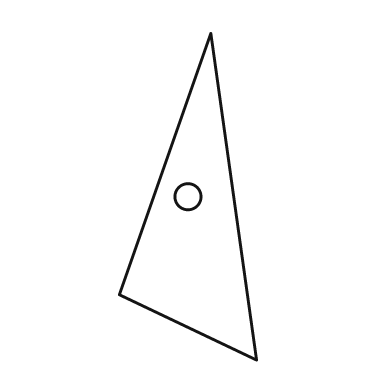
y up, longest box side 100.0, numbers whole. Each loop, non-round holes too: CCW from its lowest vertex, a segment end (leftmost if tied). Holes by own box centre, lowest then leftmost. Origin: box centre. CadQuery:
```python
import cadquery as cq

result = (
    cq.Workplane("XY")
    .moveTo(21.0, -50.0)
    .lineTo(7.0, 50.0)
    .lineTo(-21.0, -30.0)
    .close()
    .moveTo(0.0, 0.0)
    .circle(4.0)
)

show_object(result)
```